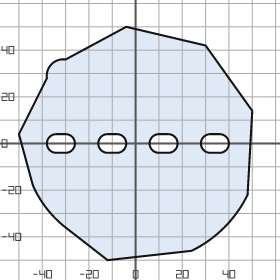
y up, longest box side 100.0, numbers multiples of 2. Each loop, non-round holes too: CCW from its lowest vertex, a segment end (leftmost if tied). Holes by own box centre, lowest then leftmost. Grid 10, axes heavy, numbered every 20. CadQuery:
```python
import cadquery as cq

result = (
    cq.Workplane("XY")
    .moveTo(-12.0, -50.0)
    .lineTo(24.0, -46.0)
    .threePointArc((38.0, -36.0), (48.0, -22.0))
    .lineTo(50.0, 14.0)
    .lineTo(30.0, 42.0)
    .lineTo(-4.0, 50.0)
    .lineTo(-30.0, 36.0)
    .threePointArc((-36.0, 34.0), (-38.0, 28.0))
    .lineTo(-50.0, 4.0)
    .lineTo(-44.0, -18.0)
    .threePointArc((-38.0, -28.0), (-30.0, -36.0))
    .close()
    .moveTo(-34.0, -4.0)
    .lineTo(-30.0, -4.0)
    .threePointArc((-26.0, 0.0), (-30.0, 4.0))
    .lineTo(-34.0, 4.0)
    .threePointArc((-38.0, 0.0), (-34.0, -4.0))
    .close()
    .moveTo(-12.0, -4.0)
    .lineTo(-8.0, -4.0)
    .threePointArc((-4.0, 0.0), (-8.0, 4.0))
    .lineTo(-12.0, 4.0)
    .threePointArc((-16.0, 0.0), (-12.0, -4.0))
    .close()
    .moveTo(10.0, -4.0)
    .lineTo(14.0, -4.0)
    .threePointArc((18.0, 0.0), (14.0, 4.0))
    .lineTo(10.0, 4.0)
    .threePointArc((6.0, 0.0), (10.0, -4.0))
    .close()
    .moveTo(32.0, -4.0)
    .lineTo(36.0, -4.0)
    .threePointArc((40.0, 0.0), (36.0, 4.0))
    .lineTo(32.0, 4.0)
    .threePointArc((28.0, 0.0), (32.0, -4.0))
    .close()
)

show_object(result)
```